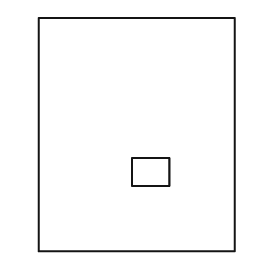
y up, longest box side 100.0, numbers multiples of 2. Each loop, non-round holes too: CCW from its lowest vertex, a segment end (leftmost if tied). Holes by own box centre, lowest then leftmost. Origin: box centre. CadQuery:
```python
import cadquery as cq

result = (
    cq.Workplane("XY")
    .moveTo(-42.0, -50.0)
    .lineTo(42.0, -50.0)
    .lineTo(42.0, 50.0)
    .lineTo(-42.0, 50.0)
    .close()
    .moveTo(-2.0, -22.0)
    .lineTo(14.0, -22.0)
    .lineTo(14.0, -10.0)
    .lineTo(-2.0, -10.0)
    .close()
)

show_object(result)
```